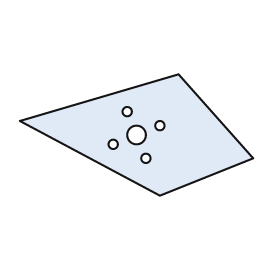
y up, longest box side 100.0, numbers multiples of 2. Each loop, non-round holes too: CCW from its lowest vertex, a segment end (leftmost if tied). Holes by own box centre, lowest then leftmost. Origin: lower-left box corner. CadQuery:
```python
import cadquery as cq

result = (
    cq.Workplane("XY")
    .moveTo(60.0, 0.0)
    .lineTo(100.0, 16.0)
    .lineTo(68.0, 52.0)
    .lineTo(0.0, 32.0)
    .close()
    .moveTo(54.0, 16.0)
    .circle(2.0)
    .moveTo(40.0, 22.0)
    .circle(2.0)
    .moveTo(50.0, 26.0)
    .circle(4.0)
    .moveTo(60.0, 30.0)
    .circle(2.0)
    .moveTo(46.0, 36.0)
    .circle(2.0)
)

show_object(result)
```